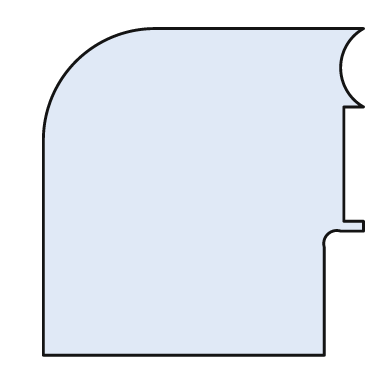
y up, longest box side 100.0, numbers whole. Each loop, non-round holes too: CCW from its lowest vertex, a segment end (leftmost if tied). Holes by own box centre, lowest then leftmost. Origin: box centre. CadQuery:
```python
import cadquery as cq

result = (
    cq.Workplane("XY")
    .moveTo(-49.0, -50.0)
    .lineTo(37.0, -50.0)
    .lineTo(37.0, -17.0)
    .threePointArc((38.0, -13.0), (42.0, -12.0))
    .lineTo(49.0, -12.0)
    .lineTo(49.0, -9.0)
    .lineTo(43.0, -9.0)
    .lineTo(43.0, 26.0)
    .lineTo(49.0, 26.0)
    .threePointArc((42.0, 38.0), (49.0, 50.0))
    .lineTo(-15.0, 50.0)
    .threePointArc((-39.0, 40.0), (-49.0, 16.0))
    .close()
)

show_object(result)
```